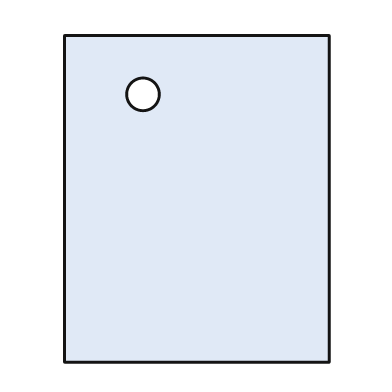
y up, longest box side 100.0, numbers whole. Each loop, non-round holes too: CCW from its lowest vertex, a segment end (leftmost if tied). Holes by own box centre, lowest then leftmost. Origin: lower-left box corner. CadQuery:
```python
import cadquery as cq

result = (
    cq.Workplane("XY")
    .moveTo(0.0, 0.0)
    .lineTo(81.0, 0.0)
    .lineTo(81.0, 100.0)
    .lineTo(0.0, 100.0)
    .close()
    .moveTo(24.0, 82.0)
    .circle(5.0)
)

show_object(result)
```